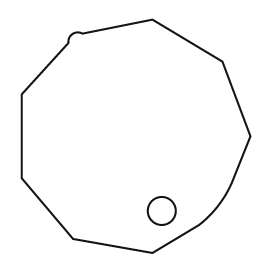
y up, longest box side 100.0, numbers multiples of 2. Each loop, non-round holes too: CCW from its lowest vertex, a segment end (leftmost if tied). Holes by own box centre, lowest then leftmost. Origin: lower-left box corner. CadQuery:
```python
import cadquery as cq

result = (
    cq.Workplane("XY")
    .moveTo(56.0, 0.0)
    .lineTo(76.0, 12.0)
    .threePointArc((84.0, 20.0), (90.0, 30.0))
    .lineTo(98.0, 50.0)
    .lineTo(86.0, 82.0)
    .lineTo(56.0, 100.0)
    .lineTo(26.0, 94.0)
    .threePointArc((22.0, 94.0), (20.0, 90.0))
    .lineTo(0.0, 68.0)
    .lineTo(0.0, 32.0)
    .lineTo(22.0, 6.0)
    .close()
    .moveTo(60.0, 18.0)
    .circle(6.0)
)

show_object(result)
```